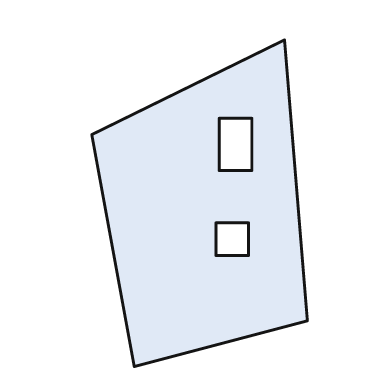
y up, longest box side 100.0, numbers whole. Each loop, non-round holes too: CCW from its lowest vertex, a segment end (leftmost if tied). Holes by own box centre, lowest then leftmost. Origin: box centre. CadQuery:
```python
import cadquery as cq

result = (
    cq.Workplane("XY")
    .moveTo(-20.0, -50.0)
    .lineTo(33.0, -36.0)
    .lineTo(26.0, 50.0)
    .lineTo(-33.0, 21.0)
    .close()
    .moveTo(5.0, -16.0)
    .lineTo(15.0, -16.0)
    .lineTo(15.0, -6.0)
    .lineTo(5.0, -6.0)
    .close()
    .moveTo(6.0, 10.0)
    .lineTo(16.0, 10.0)
    .lineTo(16.0, 26.0)
    .lineTo(6.0, 26.0)
    .close()
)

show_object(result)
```